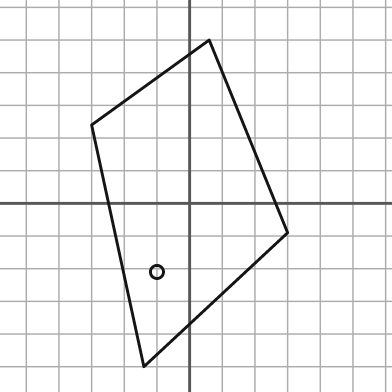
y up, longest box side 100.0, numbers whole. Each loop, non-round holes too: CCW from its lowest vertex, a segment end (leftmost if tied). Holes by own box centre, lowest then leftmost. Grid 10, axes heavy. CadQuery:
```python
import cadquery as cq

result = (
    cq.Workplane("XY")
    .moveTo(-14.0, -50.0)
    .lineTo(30.0, -9.0)
    .lineTo(6.0, 50.0)
    .lineTo(-30.0, 24.0)
    .close()
    .moveTo(-10.0, -21.0)
    .circle(2.0)
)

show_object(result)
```